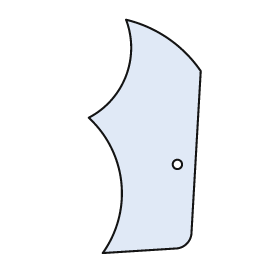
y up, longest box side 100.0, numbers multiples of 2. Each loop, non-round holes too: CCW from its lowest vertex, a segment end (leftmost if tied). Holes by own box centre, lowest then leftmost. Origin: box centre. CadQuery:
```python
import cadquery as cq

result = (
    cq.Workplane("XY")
    .moveTo(-18.0, -50.0)
    .lineTo(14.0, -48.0)
    .threePointArc((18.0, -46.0), (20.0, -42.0))
    .lineTo(24.0, 28.0)
    .threePointArc((10.0, 42.0), (-8.0, 50.0))
    .threePointArc((-8.0, 26.0), (-24.0, 8.0))
    .threePointArc((-10.0, -20.0), (-18.0, -50.0))
    .close()
    .moveTo(14.0, -12.0)
    .circle(2.0)
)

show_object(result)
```